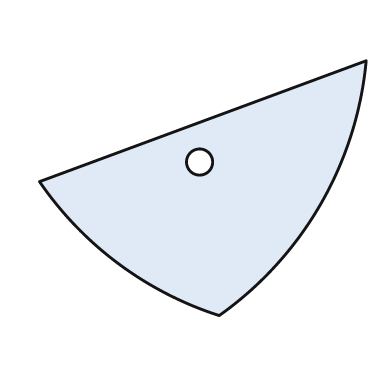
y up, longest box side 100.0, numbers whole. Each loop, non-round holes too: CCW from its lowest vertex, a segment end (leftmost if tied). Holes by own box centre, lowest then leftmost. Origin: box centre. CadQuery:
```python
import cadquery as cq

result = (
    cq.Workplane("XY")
    .moveTo(5.0, -39.0)
    .threePointArc((36.0, -5.0), (50.0, 39.0))
    .lineTo(-50.0, 2.0)
    .threePointArc((-26.0, -23.0), (5.0, -39.0))
    .close()
    .moveTo(-1.0, 8.0)
    .circle(4.0)
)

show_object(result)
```